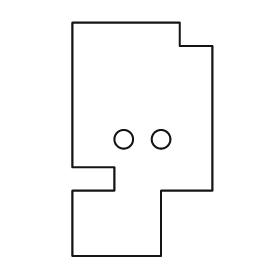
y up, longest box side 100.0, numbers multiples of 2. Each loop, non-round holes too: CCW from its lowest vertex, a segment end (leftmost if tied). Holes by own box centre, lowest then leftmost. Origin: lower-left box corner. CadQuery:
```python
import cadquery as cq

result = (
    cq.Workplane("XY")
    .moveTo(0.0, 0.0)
    .lineTo(38.0, 0.0)
    .lineTo(38.0, 28.0)
    .lineTo(60.0, 28.0)
    .lineTo(60.0, 90.0)
    .lineTo(46.0, 90.0)
    .lineTo(46.0, 100.0)
    .lineTo(0.0, 100.0)
    .lineTo(0.0, 38.0)
    .lineTo(18.0, 38.0)
    .lineTo(18.0, 28.0)
    .lineTo(0.0, 28.0)
    .close()
    .moveTo(22.0, 50.0)
    .circle(4.0)
    .moveTo(38.0, 50.0)
    .circle(4.0)
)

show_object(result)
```